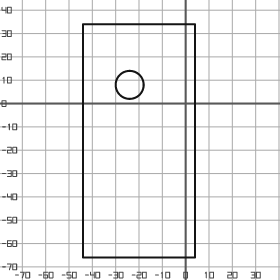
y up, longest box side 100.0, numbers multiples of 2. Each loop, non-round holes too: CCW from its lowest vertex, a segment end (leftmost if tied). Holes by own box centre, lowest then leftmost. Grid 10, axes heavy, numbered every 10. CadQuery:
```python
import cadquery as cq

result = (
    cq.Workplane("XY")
    .moveTo(-44.0, -66.0)
    .lineTo(4.0, -66.0)
    .lineTo(4.0, 34.0)
    .lineTo(-44.0, 34.0)
    .close()
    .moveTo(-24.0, 8.0)
    .circle(6.0)
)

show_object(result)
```